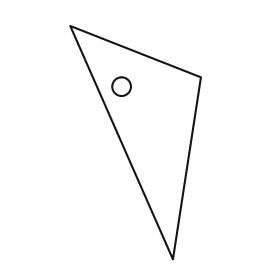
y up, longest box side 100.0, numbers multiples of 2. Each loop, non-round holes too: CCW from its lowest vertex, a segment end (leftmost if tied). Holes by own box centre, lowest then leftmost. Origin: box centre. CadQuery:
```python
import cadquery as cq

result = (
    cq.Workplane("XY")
    .moveTo(16.0, -50.0)
    .lineTo(28.0, 28.0)
    .lineTo(-28.0, 50.0)
    .close()
    .moveTo(-6.0, 24.0)
    .circle(4.0)
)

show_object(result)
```